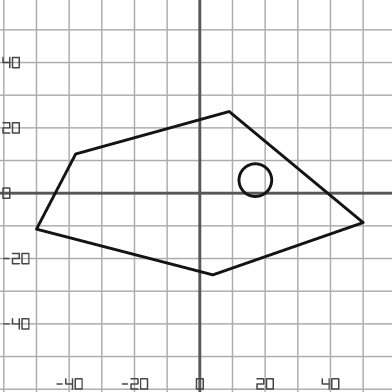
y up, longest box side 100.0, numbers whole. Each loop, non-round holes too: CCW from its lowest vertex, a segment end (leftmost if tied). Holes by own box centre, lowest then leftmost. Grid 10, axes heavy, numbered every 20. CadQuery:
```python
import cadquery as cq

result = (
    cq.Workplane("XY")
    .moveTo(4.0, -25.0)
    .lineTo(50.0, -9.0)
    .lineTo(9.0, 25.0)
    .lineTo(-38.0, 12.0)
    .lineTo(-50.0, -11.0)
    .close()
    .moveTo(17.0, 4.0)
    .circle(5.0)
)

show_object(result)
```